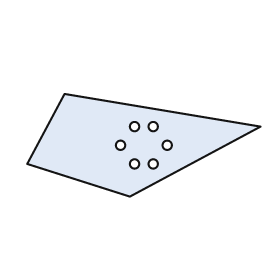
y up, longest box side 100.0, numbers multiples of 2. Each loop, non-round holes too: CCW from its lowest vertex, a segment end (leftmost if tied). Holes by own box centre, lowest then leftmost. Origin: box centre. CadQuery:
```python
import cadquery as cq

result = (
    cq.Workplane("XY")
    .moveTo(-6.0, -22.0)
    .lineTo(50.0, 8.0)
    .lineTo(-34.0, 22.0)
    .lineTo(-50.0, -8.0)
    .close()
    .moveTo(-4.0, -8.0)
    .circle(2.0)
    .moveTo(4.0, -8.0)
    .circle(2.0)
    .moveTo(-10.0, 0.0)
    .circle(2.0)
    .moveTo(10.0, 0.0)
    .circle(2.0)
    .moveTo(-4.0, 8.0)
    .circle(2.0)
    .moveTo(4.0, 8.0)
    .circle(2.0)
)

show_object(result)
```